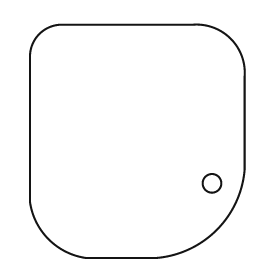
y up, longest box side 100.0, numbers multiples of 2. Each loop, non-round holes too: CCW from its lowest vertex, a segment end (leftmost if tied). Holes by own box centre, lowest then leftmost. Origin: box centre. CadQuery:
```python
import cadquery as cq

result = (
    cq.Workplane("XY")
    .moveTo(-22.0, -50.0)
    .lineTo(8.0, -50.0)
    .threePointArc((34.0, -38.0), (46.0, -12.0))
    .lineTo(46.0, 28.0)
    .threePointArc((40.0, 44.0), (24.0, 50.0))
    .lineTo(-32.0, 50.0)
    .threePointArc((-42.0, 46.0), (-46.0, 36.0))
    .lineTo(-46.0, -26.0)
    .threePointArc((-38.0, -42.0), (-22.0, -50.0))
    .close()
    .moveTo(32.0, -18.0)
    .circle(4.0)
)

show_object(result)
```